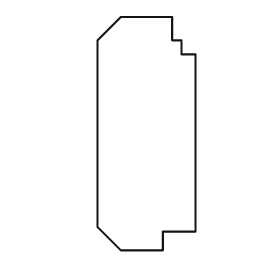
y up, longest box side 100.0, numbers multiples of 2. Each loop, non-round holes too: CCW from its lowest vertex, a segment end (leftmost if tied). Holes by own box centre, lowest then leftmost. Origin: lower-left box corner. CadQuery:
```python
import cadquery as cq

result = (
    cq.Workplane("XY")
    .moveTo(10.0, 0.0)
    .lineTo(28.0, 0.0)
    .lineTo(28.0, 8.0)
    .lineTo(42.0, 8.0)
    .lineTo(42.0, 84.0)
    .lineTo(36.0, 84.0)
    .lineTo(36.0, 90.0)
    .lineTo(32.0, 90.0)
    .lineTo(32.0, 100.0)
    .lineTo(10.0, 100.0)
    .lineTo(0.0, 90.0)
    .lineTo(0.0, 10.0)
    .close()
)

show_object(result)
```